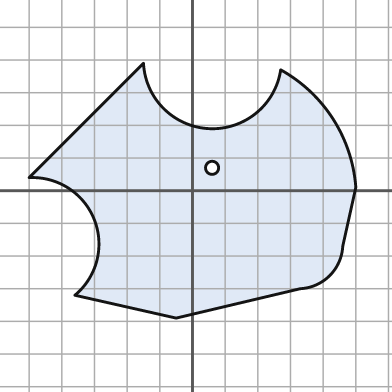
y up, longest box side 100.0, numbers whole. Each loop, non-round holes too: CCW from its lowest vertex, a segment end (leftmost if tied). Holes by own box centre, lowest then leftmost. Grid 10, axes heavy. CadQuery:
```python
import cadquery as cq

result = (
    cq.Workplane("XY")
    .moveTo(-5.0, -39.0)
    .lineTo(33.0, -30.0)
    .threePointArc((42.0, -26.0), (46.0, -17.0))
    .lineTo(50.0, 1.0)
    .threePointArc((43.0, 22.0), (27.0, 37.0))
    .threePointArc((5.0, 19.0), (-15.0, 39.0))
    .lineTo(-50.0, 4.0)
    .threePointArc((-30.0, -9.0), (-36.0, -32.0))
    .close()
    .moveTo(6.0, 7.0)
    .circle(2.0)
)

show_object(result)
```